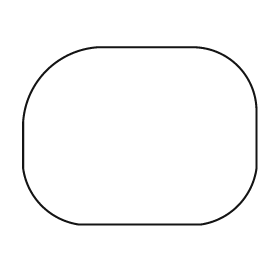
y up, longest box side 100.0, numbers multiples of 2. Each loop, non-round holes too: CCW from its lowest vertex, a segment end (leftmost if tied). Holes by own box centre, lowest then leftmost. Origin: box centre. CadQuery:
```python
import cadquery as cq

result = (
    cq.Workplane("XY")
    .moveTo(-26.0, -38.0)
    .lineTo(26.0, -38.0)
    .threePointArc((42.0, -30.0), (50.0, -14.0))
    .lineTo(50.0, 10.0)
    .threePointArc((42.0, 30.0), (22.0, 38.0))
    .lineTo(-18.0, 38.0)
    .threePointArc((-40.0, 28.0), (-50.0, 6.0))
    .lineTo(-50.0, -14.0)
    .threePointArc((-42.0, -30.0), (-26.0, -38.0))
    .close()
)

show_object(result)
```